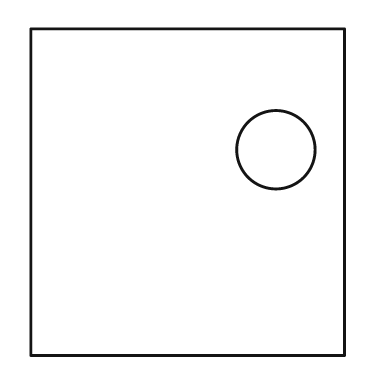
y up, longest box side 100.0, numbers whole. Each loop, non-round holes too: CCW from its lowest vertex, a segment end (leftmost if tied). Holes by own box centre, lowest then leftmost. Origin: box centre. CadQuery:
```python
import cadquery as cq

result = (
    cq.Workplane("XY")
    .moveTo(-48.0, -50.0)
    .lineTo(48.0, -50.0)
    .lineTo(48.0, 50.0)
    .lineTo(-48.0, 50.0)
    .close()
    .moveTo(27.0, 13.0)
    .circle(12.0)
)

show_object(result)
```